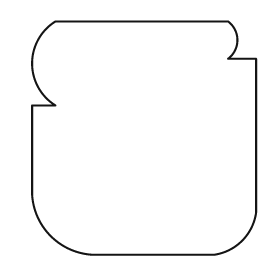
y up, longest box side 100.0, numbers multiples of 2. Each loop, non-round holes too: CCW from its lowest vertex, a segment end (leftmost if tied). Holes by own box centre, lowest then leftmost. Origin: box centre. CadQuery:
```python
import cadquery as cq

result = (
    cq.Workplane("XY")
    .moveTo(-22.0, -50.0)
    .lineTo(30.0, -50.0)
    .threePointArc((42.0, -44.0), (48.0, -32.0))
    .lineTo(48.0, 34.0)
    .lineTo(36.0, 34.0)
    .threePointArc((40.0, 42.0), (36.0, 50.0))
    .lineTo(-38.0, 50.0)
    .threePointArc((-48.0, 32.0), (-38.0, 14.0))
    .lineTo(-48.0, 14.0)
    .lineTo(-48.0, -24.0)
    .threePointArc((-40.0, -42.0), (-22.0, -50.0))
    .close()
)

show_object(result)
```